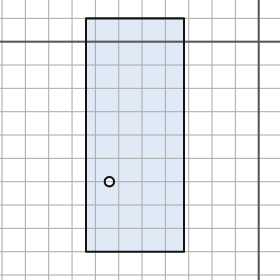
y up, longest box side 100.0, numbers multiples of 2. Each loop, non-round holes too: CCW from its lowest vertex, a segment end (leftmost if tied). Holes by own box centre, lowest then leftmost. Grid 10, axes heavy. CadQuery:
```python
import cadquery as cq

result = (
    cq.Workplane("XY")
    .moveTo(-74.0, -90.0)
    .lineTo(-32.0, -90.0)
    .lineTo(-32.0, 10.0)
    .lineTo(-74.0, 10.0)
    .close()
    .moveTo(-64.0, -60.0)
    .circle(2.0)
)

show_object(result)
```